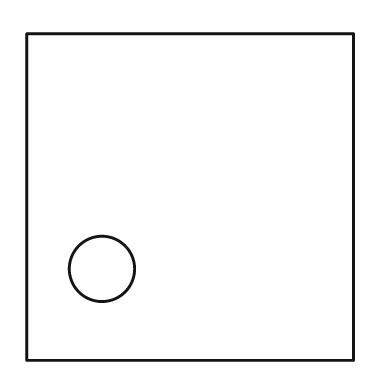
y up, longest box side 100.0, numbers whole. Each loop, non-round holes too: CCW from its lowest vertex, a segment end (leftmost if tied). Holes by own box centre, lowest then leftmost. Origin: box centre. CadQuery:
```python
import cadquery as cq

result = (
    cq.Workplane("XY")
    .moveTo(-50.0, -50.0)
    .lineTo(50.0, -50.0)
    .lineTo(50.0, 50.0)
    .lineTo(-50.0, 50.0)
    .close()
    .moveTo(-27.0, -22.0)
    .circle(10.0)
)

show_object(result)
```